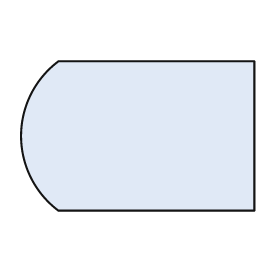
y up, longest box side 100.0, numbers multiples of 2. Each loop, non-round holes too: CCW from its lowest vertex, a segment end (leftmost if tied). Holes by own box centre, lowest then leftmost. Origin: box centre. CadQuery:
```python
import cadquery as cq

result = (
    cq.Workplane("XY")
    .moveTo(-34.0, -32.0)
    .lineTo(50.0, -32.0)
    .lineTo(50.0, 32.0)
    .lineTo(-34.0, 32.0)
    .threePointArc((-50.0, 0.0), (-34.0, -32.0))
    .close()
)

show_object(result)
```